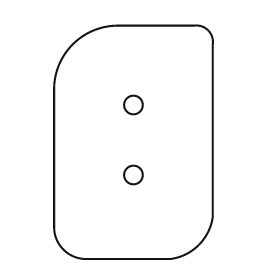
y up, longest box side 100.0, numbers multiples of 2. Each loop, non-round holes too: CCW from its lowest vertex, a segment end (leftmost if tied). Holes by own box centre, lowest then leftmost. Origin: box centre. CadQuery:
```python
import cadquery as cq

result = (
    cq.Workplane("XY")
    .moveTo(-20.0, -50.0)
    .lineTo(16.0, -50.0)
    .threePointArc((28.0, -44.0), (34.0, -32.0))
    .lineTo(34.0, 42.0)
    .threePointArc((32.0, 48.0), (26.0, 50.0))
    .lineTo(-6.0, 50.0)
    .threePointArc((-26.0, 42.0), (-34.0, 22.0))
    .lineTo(-34.0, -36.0)
    .threePointArc((-30.0, -46.0), (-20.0, -50.0))
    .close()
    .moveTo(0.0, -14.0)
    .circle(4.0)
    .moveTo(0.0, 16.0)
    .circle(4.0)
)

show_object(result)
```